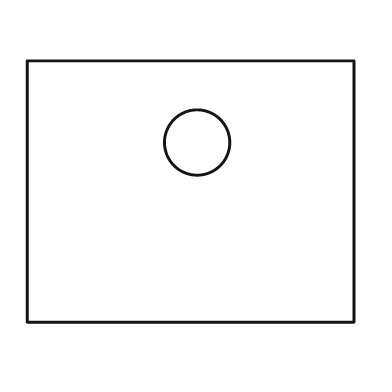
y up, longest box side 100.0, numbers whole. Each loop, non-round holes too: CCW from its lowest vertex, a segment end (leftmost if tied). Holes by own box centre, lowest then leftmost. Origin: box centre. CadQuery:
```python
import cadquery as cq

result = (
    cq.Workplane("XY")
    .moveTo(-50.0, -40.0)
    .lineTo(50.0, -40.0)
    .lineTo(50.0, 40.0)
    .lineTo(-50.0, 40.0)
    .close()
    .moveTo(2.0, 15.0)
    .circle(10.0)
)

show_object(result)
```